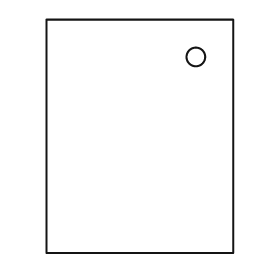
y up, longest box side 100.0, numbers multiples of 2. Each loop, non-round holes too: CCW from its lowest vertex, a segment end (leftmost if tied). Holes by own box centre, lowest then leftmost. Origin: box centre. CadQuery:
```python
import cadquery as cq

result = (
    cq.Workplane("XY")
    .moveTo(-40.0, -50.0)
    .lineTo(40.0, -50.0)
    .lineTo(40.0, 50.0)
    .lineTo(-40.0, 50.0)
    .close()
    .moveTo(24.0, 34.0)
    .circle(4.0)
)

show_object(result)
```